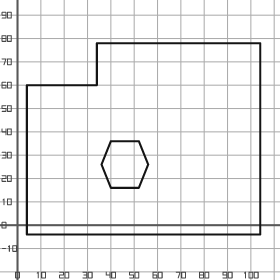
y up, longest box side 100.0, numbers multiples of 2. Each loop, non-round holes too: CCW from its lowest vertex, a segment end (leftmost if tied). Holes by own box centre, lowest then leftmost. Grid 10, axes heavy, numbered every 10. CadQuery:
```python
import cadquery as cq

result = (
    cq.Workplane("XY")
    .moveTo(4.0, -4.0)
    .lineTo(104.0, -4.0)
    .lineTo(104.0, 78.0)
    .lineTo(34.0, 78.0)
    .lineTo(34.0, 60.0)
    .lineTo(4.0, 60.0)
    .close()
    .moveTo(40.0, 16.0)
    .lineTo(52.0, 16.0)
    .lineTo(56.0, 26.0)
    .lineTo(52.0, 36.0)
    .lineTo(40.0, 36.0)
    .lineTo(36.0, 26.0)
    .close()
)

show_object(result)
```